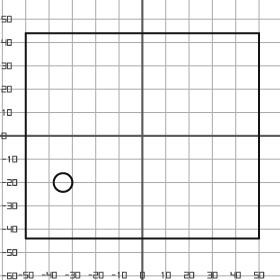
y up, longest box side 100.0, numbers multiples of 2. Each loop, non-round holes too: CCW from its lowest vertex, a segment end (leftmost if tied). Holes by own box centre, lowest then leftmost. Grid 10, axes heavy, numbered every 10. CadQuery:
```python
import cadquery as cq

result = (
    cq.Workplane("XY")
    .moveTo(-50.0, -44.0)
    .lineTo(50.0, -44.0)
    .lineTo(50.0, 44.0)
    .lineTo(-50.0, 44.0)
    .close()
    .moveTo(-34.0, -20.0)
    .circle(4.0)
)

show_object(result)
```